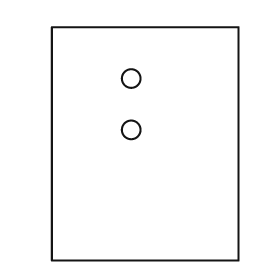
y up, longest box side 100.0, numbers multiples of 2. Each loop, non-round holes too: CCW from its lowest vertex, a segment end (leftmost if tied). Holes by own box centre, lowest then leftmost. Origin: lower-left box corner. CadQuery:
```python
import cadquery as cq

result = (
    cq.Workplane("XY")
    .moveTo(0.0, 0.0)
    .lineTo(80.0, 0.0)
    .lineTo(80.0, 100.0)
    .lineTo(0.0, 100.0)
    .close()
    .moveTo(34.0, 56.0)
    .circle(4.0)
    .moveTo(34.0, 78.0)
    .circle(4.0)
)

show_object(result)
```